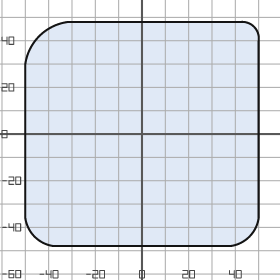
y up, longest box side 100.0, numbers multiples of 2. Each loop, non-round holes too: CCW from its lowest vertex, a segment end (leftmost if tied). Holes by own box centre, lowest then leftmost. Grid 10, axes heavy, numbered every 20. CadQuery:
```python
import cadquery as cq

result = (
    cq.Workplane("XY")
    .moveTo(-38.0, -48.0)
    .lineTo(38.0, -48.0)
    .threePointArc((46.0, -44.0), (50.0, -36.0))
    .lineTo(50.0, 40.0)
    .threePointArc((48.0, 46.0), (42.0, 48.0))
    .lineTo(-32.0, 48.0)
    .threePointArc((-44.0, 42.0), (-50.0, 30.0))
    .lineTo(-50.0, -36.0)
    .threePointArc((-46.0, -44.0), (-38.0, -48.0))
    .close()
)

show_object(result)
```